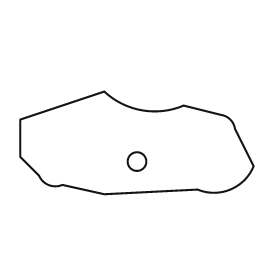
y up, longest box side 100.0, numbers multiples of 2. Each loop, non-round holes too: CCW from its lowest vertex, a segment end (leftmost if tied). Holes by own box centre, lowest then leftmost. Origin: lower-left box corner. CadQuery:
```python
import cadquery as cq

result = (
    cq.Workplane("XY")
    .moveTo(36.0, 0.0)
    .lineTo(76.0, 2.0)
    .threePointArc((90.0, 2.0), (100.0, 12.0))
    .lineTo(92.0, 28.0)
    .threePointArc((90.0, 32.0), (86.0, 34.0))
    .lineTo(70.0, 38.0)
    .threePointArc((52.0, 36.0), (36.0, 44.0))
    .lineTo(0.0, 32.0)
    .lineTo(0.0, 16.0)
    .lineTo(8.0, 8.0)
    .threePointArc((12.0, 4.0), (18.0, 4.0))
    .close()
    .moveTo(50.0, 14.0)
    .circle(4.0)
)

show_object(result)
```